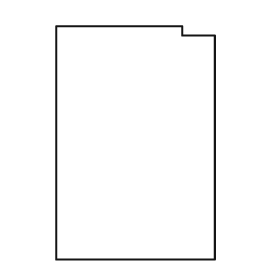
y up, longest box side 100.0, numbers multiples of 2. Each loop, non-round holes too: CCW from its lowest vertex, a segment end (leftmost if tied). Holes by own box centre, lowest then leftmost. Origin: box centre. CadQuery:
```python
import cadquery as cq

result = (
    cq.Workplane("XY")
    .moveTo(-34.0, -50.0)
    .lineTo(34.0, -50.0)
    .lineTo(34.0, 46.0)
    .lineTo(20.0, 46.0)
    .lineTo(20.0, 50.0)
    .lineTo(-34.0, 50.0)
    .close()
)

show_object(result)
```